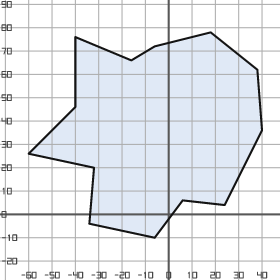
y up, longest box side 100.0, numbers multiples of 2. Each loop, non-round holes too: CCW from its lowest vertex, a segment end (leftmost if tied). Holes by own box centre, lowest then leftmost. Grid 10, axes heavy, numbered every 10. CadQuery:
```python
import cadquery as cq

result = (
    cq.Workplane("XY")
    .moveTo(-6.0, -10.0)
    .lineTo(6.0, 6.0)
    .lineTo(24.0, 4.0)
    .lineTo(40.0, 36.0)
    .lineTo(38.0, 62.0)
    .lineTo(18.0, 78.0)
    .lineTo(-6.0, 72.0)
    .lineTo(-16.0, 66.0)
    .lineTo(-40.0, 76.0)
    .lineTo(-40.0, 46.0)
    .lineTo(-60.0, 26.0)
    .lineTo(-32.0, 20.0)
    .lineTo(-34.0, -4.0)
    .close()
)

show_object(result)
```